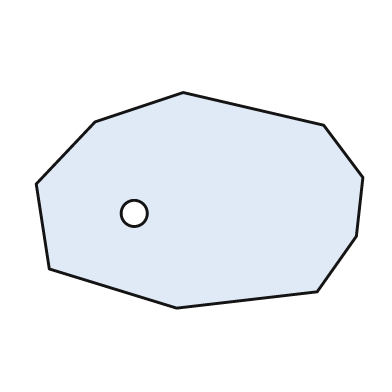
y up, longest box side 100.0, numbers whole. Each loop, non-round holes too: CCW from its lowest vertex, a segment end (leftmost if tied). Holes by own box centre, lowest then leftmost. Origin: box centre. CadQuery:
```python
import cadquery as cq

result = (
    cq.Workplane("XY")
    .moveTo(-7.0, -33.0)
    .lineTo(36.0, -28.0)
    .lineTo(48.0, -11.0)
    .lineTo(50.0, 7.0)
    .lineTo(38.0, 23.0)
    .lineTo(-5.0, 33.0)
    .lineTo(-32.0, 24.0)
    .lineTo(-50.0, 5.0)
    .lineTo(-46.0, -21.0)
    .close()
    .moveTo(-20.0, -4.0)
    .circle(4.0)
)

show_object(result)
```